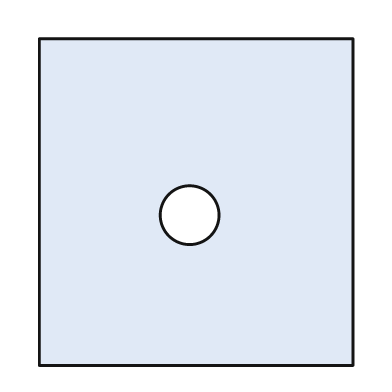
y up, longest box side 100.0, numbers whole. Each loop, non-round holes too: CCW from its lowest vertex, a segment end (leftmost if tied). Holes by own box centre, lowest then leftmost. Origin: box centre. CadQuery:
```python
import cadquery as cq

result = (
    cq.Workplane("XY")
    .moveTo(-48.0, -50.0)
    .lineTo(48.0, -50.0)
    .lineTo(48.0, 50.0)
    .lineTo(-48.0, 50.0)
    .close()
    .moveTo(-2.0, -4.0)
    .circle(9.0)
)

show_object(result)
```